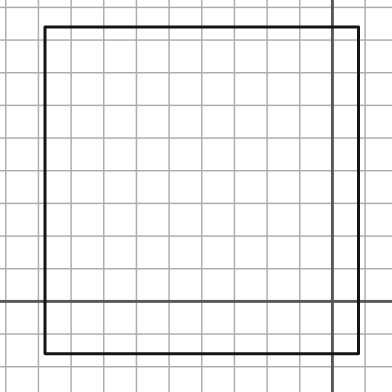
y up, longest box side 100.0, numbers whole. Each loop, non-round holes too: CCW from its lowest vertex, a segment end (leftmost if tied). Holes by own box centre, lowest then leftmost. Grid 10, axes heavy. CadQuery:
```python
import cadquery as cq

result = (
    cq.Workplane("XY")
    .moveTo(-88.0, -16.0)
    .lineTo(8.0, -16.0)
    .lineTo(8.0, 84.0)
    .lineTo(-88.0, 84.0)
    .close()
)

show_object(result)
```